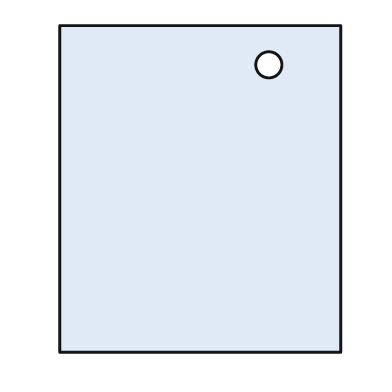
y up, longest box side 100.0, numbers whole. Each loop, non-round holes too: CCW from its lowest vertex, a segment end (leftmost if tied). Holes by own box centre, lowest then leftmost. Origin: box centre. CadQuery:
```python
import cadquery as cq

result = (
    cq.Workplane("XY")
    .moveTo(-43.0, -50.0)
    .lineTo(43.0, -50.0)
    .lineTo(43.0, 50.0)
    .lineTo(-43.0, 50.0)
    .close()
    .moveTo(21.0, 38.0)
    .circle(4.0)
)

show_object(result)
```